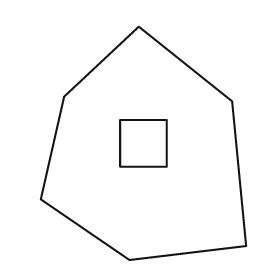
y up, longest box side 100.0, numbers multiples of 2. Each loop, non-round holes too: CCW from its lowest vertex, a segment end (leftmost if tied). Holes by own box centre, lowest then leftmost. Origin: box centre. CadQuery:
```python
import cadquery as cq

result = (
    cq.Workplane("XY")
    .moveTo(-6.0, -50.0)
    .lineTo(44.0, -44.0)
    .lineTo(38.0, 18.0)
    .lineTo(-2.0, 50.0)
    .lineTo(-34.0, 20.0)
    .lineTo(-44.0, -24.0)
    .close()
    .moveTo(-10.0, -10.0)
    .lineTo(10.0, -10.0)
    .lineTo(10.0, 10.0)
    .lineTo(-10.0, 10.0)
    .close()
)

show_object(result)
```